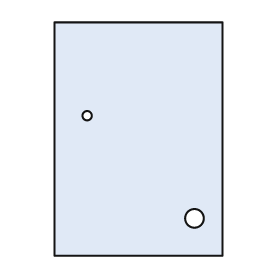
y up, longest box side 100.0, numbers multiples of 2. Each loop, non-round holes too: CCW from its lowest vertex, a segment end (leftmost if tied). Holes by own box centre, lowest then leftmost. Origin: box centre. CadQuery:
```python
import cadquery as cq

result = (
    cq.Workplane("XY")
    .moveTo(-36.0, -50.0)
    .lineTo(36.0, -50.0)
    .lineTo(36.0, 50.0)
    .lineTo(-36.0, 50.0)
    .close()
    .moveTo(24.0, -34.0)
    .circle(4.0)
    .moveTo(-22.0, 10.0)
    .circle(2.0)
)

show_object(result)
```